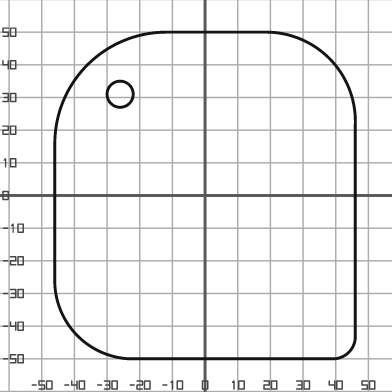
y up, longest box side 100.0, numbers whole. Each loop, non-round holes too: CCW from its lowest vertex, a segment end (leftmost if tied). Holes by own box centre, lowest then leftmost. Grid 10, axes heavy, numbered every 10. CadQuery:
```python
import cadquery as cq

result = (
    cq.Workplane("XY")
    .moveTo(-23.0, -50.0)
    .lineTo(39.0, -50.0)
    .threePointArc((44.0, -48.0), (46.0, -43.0))
    .lineTo(46.0, 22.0)
    .threePointArc((38.0, 42.0), (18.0, 50.0))
    .lineTo(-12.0, 50.0)
    .threePointArc((-36.0, 40.0), (-46.0, 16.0))
    .lineTo(-46.0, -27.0)
    .threePointArc((-39.0, -43.0), (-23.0, -50.0))
    .close()
    .moveTo(-26.0, 31.0)
    .circle(4.0)
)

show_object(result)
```